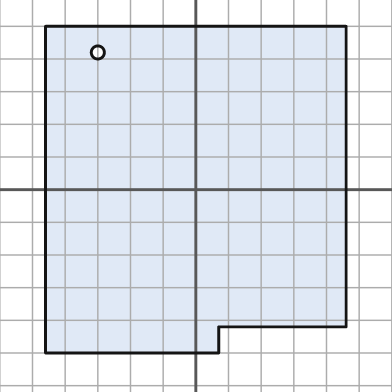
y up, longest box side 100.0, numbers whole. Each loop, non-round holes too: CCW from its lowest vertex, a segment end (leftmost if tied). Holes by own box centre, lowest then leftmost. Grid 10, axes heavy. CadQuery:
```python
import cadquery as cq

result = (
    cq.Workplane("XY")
    .moveTo(-46.0, -50.0)
    .lineTo(7.0, -50.0)
    .lineTo(7.0, -42.0)
    .lineTo(46.0, -42.0)
    .lineTo(46.0, 50.0)
    .lineTo(-46.0, 50.0)
    .close()
    .moveTo(-30.0, 42.0)
    .circle(2.0)
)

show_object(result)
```